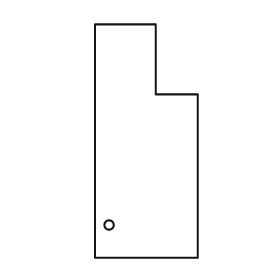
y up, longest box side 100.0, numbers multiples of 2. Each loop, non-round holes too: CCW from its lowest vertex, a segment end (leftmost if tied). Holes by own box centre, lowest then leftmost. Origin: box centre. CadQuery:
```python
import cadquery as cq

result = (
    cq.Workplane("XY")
    .moveTo(-22.0, -50.0)
    .lineTo(22.0, -50.0)
    .lineTo(22.0, 20.0)
    .lineTo(4.0, 20.0)
    .lineTo(4.0, 50.0)
    .lineTo(-22.0, 50.0)
    .close()
    .moveTo(-16.0, -36.0)
    .circle(2.0)
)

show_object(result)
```